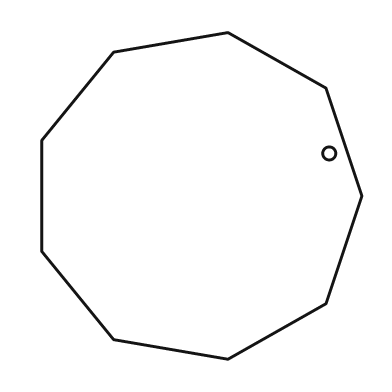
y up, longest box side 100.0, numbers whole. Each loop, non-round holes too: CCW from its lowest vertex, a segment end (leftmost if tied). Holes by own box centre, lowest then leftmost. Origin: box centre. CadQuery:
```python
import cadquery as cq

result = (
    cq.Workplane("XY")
    .moveTo(8.0, -50.0)
    .lineTo(38.0, -33.0)
    .lineTo(49.0, 0.0)
    .lineTo(38.0, 33.0)
    .lineTo(8.0, 50.0)
    .lineTo(-27.0, 44.0)
    .lineTo(-49.0, 17.0)
    .lineTo(-49.0, -17.0)
    .lineTo(-27.0, -44.0)
    .close()
    .moveTo(39.0, 13.0)
    .circle(2.0)
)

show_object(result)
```